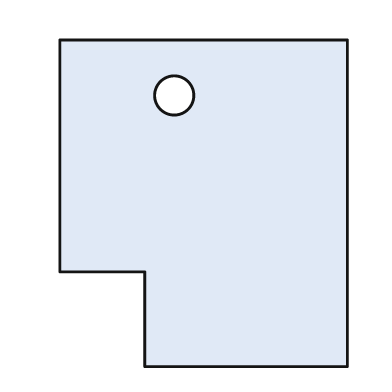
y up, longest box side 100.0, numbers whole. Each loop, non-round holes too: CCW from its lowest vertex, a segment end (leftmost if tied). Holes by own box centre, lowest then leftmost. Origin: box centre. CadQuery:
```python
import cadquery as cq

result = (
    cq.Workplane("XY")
    .moveTo(-18.0, -50.0)
    .lineTo(44.0, -50.0)
    .lineTo(44.0, 50.0)
    .lineTo(-44.0, 50.0)
    .lineTo(-44.0, -21.0)
    .lineTo(-18.0, -21.0)
    .close()
    .moveTo(-9.0, 33.0)
    .circle(6.0)
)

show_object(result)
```